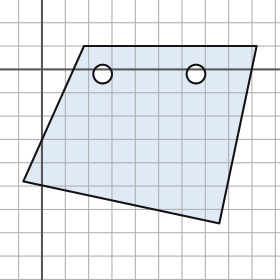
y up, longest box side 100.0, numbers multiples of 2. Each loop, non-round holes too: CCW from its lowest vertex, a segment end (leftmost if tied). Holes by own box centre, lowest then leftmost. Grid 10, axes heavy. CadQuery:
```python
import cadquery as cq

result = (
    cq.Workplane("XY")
    .moveTo(76.0, -66.0)
    .lineTo(92.0, 10.0)
    .lineTo(18.0, 10.0)
    .lineTo(-8.0, -48.0)
    .close()
    .moveTo(26.0, -2.0)
    .circle(4.0)
    .moveTo(66.0, -2.0)
    .circle(4.0)
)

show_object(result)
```